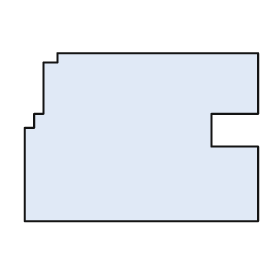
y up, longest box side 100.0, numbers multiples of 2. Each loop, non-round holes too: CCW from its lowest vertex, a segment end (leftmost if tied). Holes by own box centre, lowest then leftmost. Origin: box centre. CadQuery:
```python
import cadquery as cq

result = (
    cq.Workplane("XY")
    .moveTo(-50.0, -36.0)
    .lineTo(50.0, -36.0)
    .lineTo(50.0, -4.0)
    .lineTo(30.0, -4.0)
    .lineTo(30.0, 10.0)
    .lineTo(50.0, 10.0)
    .lineTo(50.0, 36.0)
    .lineTo(-36.0, 36.0)
    .lineTo(-36.0, 32.0)
    .lineTo(-42.0, 32.0)
    .lineTo(-42.0, 10.0)
    .lineTo(-46.0, 10.0)
    .lineTo(-46.0, 4.0)
    .lineTo(-50.0, 4.0)
    .close()
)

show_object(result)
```